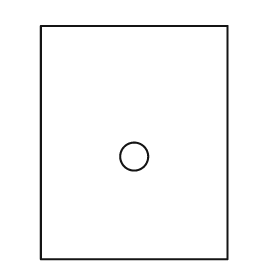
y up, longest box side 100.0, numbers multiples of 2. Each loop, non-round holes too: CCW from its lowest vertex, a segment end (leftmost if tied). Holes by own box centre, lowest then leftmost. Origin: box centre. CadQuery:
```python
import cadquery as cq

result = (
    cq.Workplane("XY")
    .moveTo(-40.0, -50.0)
    .lineTo(40.0, -50.0)
    .lineTo(40.0, 50.0)
    .lineTo(-40.0, 50.0)
    .close()
    .moveTo(0.0, -6.0)
    .circle(6.0)
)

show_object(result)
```